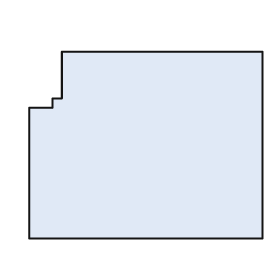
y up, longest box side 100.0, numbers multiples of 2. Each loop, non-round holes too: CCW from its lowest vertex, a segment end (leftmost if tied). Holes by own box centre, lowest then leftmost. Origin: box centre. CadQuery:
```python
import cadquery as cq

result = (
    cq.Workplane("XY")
    .moveTo(-50.0, -40.0)
    .lineTo(50.0, -40.0)
    .lineTo(50.0, 40.0)
    .lineTo(-36.0, 40.0)
    .lineTo(-36.0, 20.0)
    .lineTo(-40.0, 20.0)
    .lineTo(-40.0, 16.0)
    .lineTo(-50.0, 16.0)
    .close()
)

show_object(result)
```